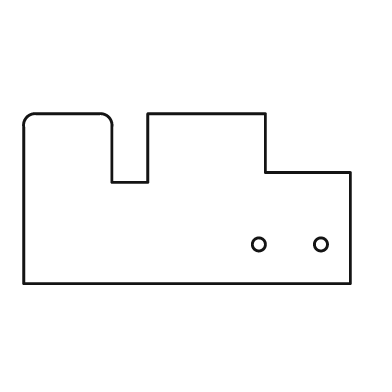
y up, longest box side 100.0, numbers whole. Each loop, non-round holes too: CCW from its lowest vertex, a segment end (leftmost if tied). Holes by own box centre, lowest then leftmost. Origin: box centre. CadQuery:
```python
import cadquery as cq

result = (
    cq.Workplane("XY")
    .moveTo(-50.0, -26.0)
    .lineTo(50.0, -26.0)
    .lineTo(50.0, 8.0)
    .lineTo(24.0, 8.0)
    .lineTo(24.0, 26.0)
    .lineTo(-12.0, 26.0)
    .lineTo(-12.0, 5.0)
    .lineTo(-23.0, 5.0)
    .lineTo(-23.0, 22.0)
    .threePointArc((-24.0, 25.0), (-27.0, 26.0))
    .lineTo(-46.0, 26.0)
    .threePointArc((-49.0, 25.0), (-50.0, 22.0))
    .close()
    .moveTo(22.0, -14.0)
    .circle(2.0)
    .moveTo(41.0, -14.0)
    .circle(2.0)
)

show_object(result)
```